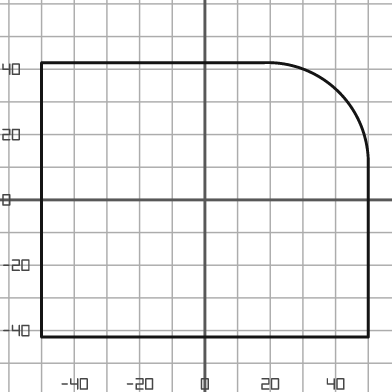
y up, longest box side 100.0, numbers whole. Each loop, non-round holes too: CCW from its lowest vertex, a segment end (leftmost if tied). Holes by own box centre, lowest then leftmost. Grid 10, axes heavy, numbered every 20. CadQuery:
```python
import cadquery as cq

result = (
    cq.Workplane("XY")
    .moveTo(-50.0, -42.0)
    .lineTo(50.0, -42.0)
    .lineTo(50.0, 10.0)
    .threePointArc((41.0, 33.0), (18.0, 42.0))
    .lineTo(-50.0, 42.0)
    .close()
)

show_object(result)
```